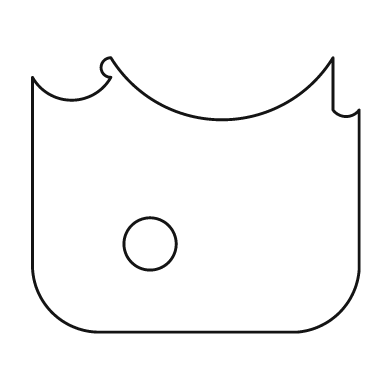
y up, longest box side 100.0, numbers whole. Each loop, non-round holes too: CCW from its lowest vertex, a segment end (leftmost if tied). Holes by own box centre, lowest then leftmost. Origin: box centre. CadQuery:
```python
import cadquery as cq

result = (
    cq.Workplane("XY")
    .moveTo(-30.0, -42.0)
    .lineTo(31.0, -42.0)
    .threePointArc((44.0, -36.0), (50.0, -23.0))
    .lineTo(50.0, 26.0)
    .threePointArc((46.0, 24.0), (42.0, 26.0))
    .lineTo(42.0, 42.0)
    .threePointArc((8.0, 23.0), (-26.0, 42.0))
    .threePointArc((-29.0, 39.0), (-26.0, 36.0))
    .threePointArc((-38.0, 29.0), (-50.0, 36.0))
    .lineTo(-50.0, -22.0)
    .threePointArc((-44.0, -36.0), (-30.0, -42.0))
    .close()
    .moveTo(-14.0, -15.0)
    .circle(8.0)
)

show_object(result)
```